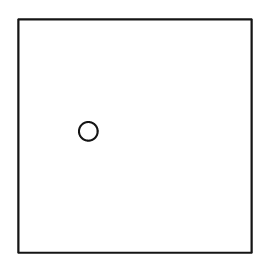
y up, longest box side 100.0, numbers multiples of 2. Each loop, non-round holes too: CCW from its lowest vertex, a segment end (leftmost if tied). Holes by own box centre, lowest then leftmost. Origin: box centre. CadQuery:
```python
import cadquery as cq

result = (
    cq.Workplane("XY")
    .moveTo(-50.0, -50.0)
    .lineTo(50.0, -50.0)
    .lineTo(50.0, 50.0)
    .lineTo(-50.0, 50.0)
    .close()
    .moveTo(-20.0, 2.0)
    .circle(4.0)
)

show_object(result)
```